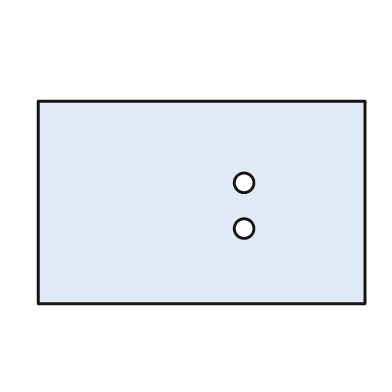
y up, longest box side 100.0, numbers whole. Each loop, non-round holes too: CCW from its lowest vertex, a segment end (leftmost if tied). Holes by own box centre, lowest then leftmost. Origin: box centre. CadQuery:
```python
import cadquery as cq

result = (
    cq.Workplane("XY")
    .moveTo(-50.0, -31.0)
    .lineTo(50.0, -31.0)
    .lineTo(50.0, 31.0)
    .lineTo(-50.0, 31.0)
    .close()
    .moveTo(13.0, -8.0)
    .circle(3.0)
    .moveTo(13.0, 6.0)
    .circle(3.0)
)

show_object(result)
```